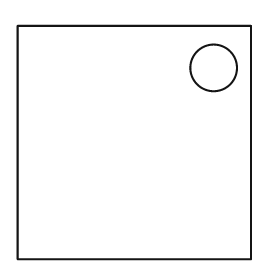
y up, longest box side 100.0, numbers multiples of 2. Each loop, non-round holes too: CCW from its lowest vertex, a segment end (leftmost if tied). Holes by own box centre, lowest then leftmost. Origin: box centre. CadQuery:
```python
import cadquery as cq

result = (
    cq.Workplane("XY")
    .moveTo(-50.0, -50.0)
    .lineTo(50.0, -50.0)
    .lineTo(50.0, 50.0)
    .lineTo(-50.0, 50.0)
    .close()
    .moveTo(34.0, 32.0)
    .circle(10.0)
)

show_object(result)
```